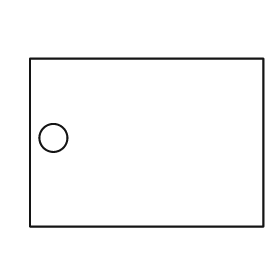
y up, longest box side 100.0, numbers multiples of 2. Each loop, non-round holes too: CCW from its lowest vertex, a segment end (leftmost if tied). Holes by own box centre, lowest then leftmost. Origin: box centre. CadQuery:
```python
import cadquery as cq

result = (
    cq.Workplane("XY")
    .moveTo(-50.0, -36.0)
    .lineTo(50.0, -36.0)
    .lineTo(50.0, 36.0)
    .lineTo(-50.0, 36.0)
    .close()
    .moveTo(-40.0, 2.0)
    .circle(6.0)
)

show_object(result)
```